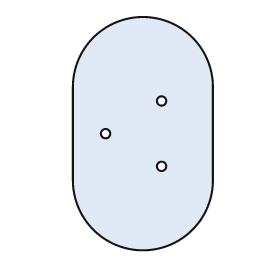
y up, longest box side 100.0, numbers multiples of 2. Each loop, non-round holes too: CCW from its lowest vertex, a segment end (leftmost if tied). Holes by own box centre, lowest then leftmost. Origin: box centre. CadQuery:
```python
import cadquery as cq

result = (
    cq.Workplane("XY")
    .moveTo(-30.0, -20.0)
    .threePointArc((0.0, -50.0), (30.0, -20.0))
    .lineTo(30.0, 20.0)
    .threePointArc((0.0, 50.0), (-30.0, 20.0))
    .close()
    .moveTo(8.0, -14.0)
    .circle(2.0)
    .moveTo(-16.0, 0.0)
    .circle(2.0)
    .moveTo(8.0, 14.0)
    .circle(2.0)
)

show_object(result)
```